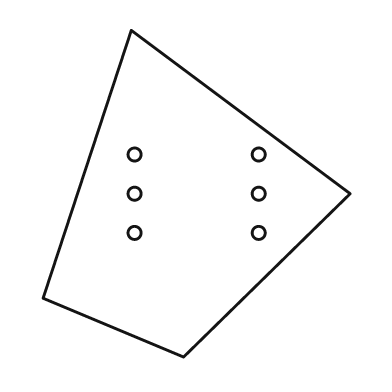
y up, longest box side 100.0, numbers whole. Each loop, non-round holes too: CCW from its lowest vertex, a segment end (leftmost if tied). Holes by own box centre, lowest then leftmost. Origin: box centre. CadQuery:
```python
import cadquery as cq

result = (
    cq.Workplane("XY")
    .moveTo(-4.0, -50.0)
    .lineTo(47.0, 0.0)
    .lineTo(-20.0, 50.0)
    .lineTo(-47.0, -32.0)
    .close()
    .moveTo(-19.0, -12.0)
    .circle(2.0)
    .moveTo(19.0, -12.0)
    .circle(2.0)
    .moveTo(-19.0, 0.0)
    .circle(2.0)
    .moveTo(19.0, 0.0)
    .circle(2.0)
    .moveTo(-19.0, 12.0)
    .circle(2.0)
    .moveTo(19.0, 12.0)
    .circle(2.0)
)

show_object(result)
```